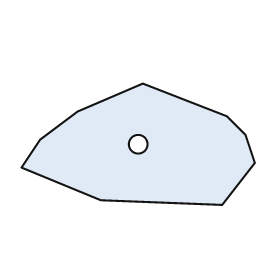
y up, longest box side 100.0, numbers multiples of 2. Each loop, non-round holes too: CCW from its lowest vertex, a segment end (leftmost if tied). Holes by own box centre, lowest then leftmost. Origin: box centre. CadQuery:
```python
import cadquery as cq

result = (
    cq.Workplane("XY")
    .moveTo(36.0, -26.0)
    .lineTo(50.0, -8.0)
    .lineTo(46.0, 4.0)
    .lineTo(38.0, 12.0)
    .lineTo(2.0, 26.0)
    .lineTo(-26.0, 14.0)
    .lineTo(-42.0, 2.0)
    .lineTo(-50.0, -10.0)
    .lineTo(-16.0, -24.0)
    .close()
    .moveTo(0.0, 0.0)
    .circle(4.0)
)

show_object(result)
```